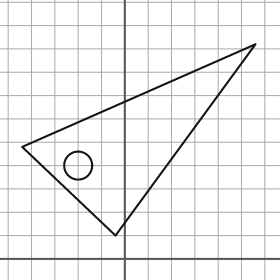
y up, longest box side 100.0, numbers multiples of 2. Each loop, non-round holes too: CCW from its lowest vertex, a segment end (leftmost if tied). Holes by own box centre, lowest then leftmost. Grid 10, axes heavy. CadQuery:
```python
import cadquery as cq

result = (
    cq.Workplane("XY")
    .moveTo(-4.0, 10.0)
    .lineTo(56.0, 92.0)
    .lineTo(-44.0, 48.0)
    .close()
    .moveTo(-20.0, 40.0)
    .circle(6.0)
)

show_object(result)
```